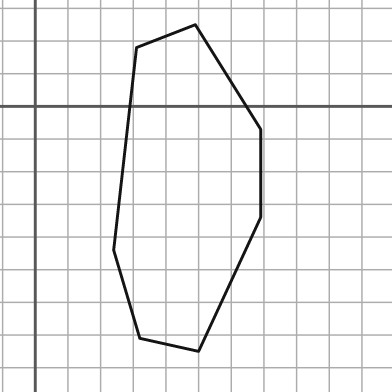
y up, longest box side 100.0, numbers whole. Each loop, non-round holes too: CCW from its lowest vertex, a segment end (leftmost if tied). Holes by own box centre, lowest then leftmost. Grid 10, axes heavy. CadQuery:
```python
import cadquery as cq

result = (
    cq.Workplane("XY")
    .moveTo(50.0, -75.0)
    .lineTo(69.0, -34.0)
    .lineTo(69.0, -7.0)
    .lineTo(49.0, 25.0)
    .lineTo(31.0, 18.0)
    .lineTo(24.0, -44.0)
    .lineTo(32.0, -71.0)
    .close()
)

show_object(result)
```